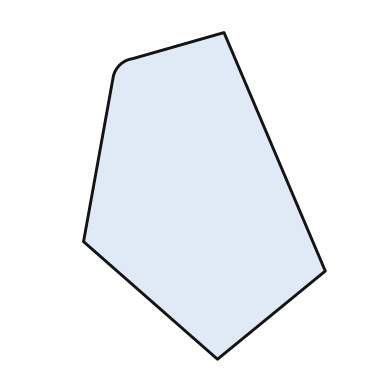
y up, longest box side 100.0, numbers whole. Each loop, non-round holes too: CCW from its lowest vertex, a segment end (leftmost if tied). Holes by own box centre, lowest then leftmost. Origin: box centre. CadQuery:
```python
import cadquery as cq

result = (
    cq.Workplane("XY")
    .moveTo(4.0, -50.0)
    .lineTo(37.0, -23.0)
    .lineTo(6.0, 50.0)
    .lineTo(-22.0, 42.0)
    .threePointArc((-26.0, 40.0), (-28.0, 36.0))
    .lineTo(-37.0, -14.0)
    .close()
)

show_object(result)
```